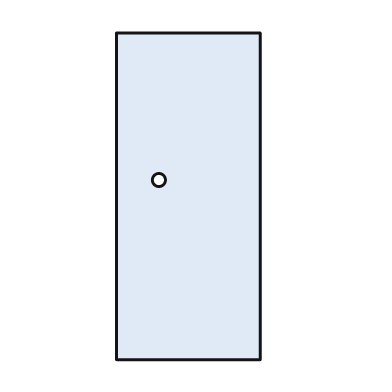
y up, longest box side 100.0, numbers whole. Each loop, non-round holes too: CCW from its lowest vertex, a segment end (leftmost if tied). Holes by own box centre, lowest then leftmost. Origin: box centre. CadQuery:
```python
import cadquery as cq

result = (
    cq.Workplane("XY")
    .moveTo(-22.0, -50.0)
    .lineTo(22.0, -50.0)
    .lineTo(22.0, 50.0)
    .lineTo(-22.0, 50.0)
    .close()
    .moveTo(-9.0, 5.0)
    .circle(2.0)
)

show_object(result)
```